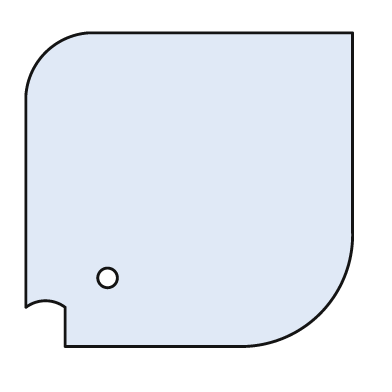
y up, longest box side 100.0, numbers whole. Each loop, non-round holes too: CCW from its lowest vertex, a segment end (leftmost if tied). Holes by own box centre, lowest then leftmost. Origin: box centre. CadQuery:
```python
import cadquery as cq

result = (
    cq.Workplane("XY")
    .moveTo(-38.0, -48.0)
    .lineTo(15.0, -48.0)
    .threePointArc((40.0, -38.0), (50.0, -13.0))
    .lineTo(50.0, 48.0)
    .lineTo(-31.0, 48.0)
    .threePointArc((-44.0, 42.0), (-50.0, 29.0))
    .lineTo(-50.0, -36.0)
    .threePointArc((-44.0, -34.0), (-38.0, -36.0))
    .close()
    .moveTo(-25.0, -27.0)
    .circle(3.0)
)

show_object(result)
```